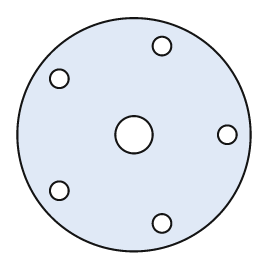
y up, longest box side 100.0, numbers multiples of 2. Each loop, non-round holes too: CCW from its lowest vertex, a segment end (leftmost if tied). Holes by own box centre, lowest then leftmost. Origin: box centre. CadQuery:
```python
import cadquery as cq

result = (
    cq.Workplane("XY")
    .moveTo(0.0, 0.0)
    .circle(50.0)
    .moveTo(12.0, -38.0)
    .circle(4.0)
    .moveTo(-32.0, -24.0)
    .circle(4.0)
    .moveTo(0.0, 0.0)
    .circle(8.0)
    .moveTo(40.0, 0.0)
    .circle(4.0)
    .moveTo(-32.0, 24.0)
    .circle(4.0)
    .moveTo(12.0, 38.0)
    .circle(4.0)
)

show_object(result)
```